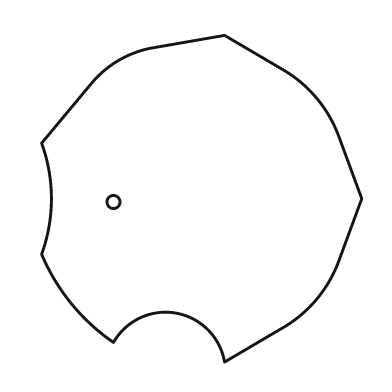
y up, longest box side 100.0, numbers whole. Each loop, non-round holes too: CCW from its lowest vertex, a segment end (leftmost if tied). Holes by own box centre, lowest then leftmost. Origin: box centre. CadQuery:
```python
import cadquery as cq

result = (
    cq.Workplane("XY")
    .moveTo(7.0, -50.0)
    .lineTo(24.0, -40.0)
    .threePointArc((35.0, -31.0), (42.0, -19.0))
    .lineTo(49.0, 0.0)
    .lineTo(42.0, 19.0)
    .threePointArc((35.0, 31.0), (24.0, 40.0))
    .lineTo(7.0, 50.0)
    .lineTo(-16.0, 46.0)
    .threePointArc((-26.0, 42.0), (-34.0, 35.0))
    .lineTo(-49.0, 17.0)
    .threePointArc((-46.0, 0.0), (-49.0, -17.0))
    .threePointArc((-40.0, -32.0), (-27.0, -44.0))
    .threePointArc((-8.0, -35.0), (7.0, -50.0))
    .close()
    .moveTo(-27.0, -1.0)
    .circle(2.0)
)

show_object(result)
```